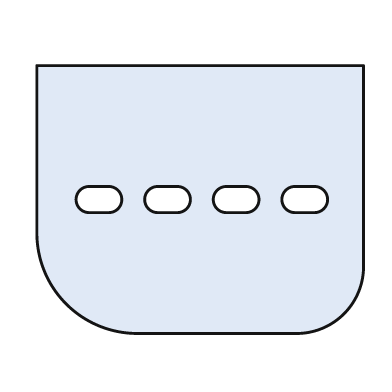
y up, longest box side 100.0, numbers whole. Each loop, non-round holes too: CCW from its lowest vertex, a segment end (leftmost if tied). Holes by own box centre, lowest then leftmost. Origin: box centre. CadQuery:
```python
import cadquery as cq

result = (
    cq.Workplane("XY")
    .moveTo(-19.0, -41.0)
    .lineTo(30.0, -41.0)
    .threePointArc((44.0, -35.0), (50.0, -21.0))
    .lineTo(50.0, 41.0)
    .lineTo(-50.0, 41.0)
    .lineTo(-50.0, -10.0)
    .threePointArc((-41.0, -32.0), (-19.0, -41.0))
    .close()
    .moveTo(-34.0, -4.0)
    .lineTo(-28.0, -4.0)
    .threePointArc((-24.0, 0.0), (-28.0, 4.0))
    .lineTo(-34.0, 4.0)
    .threePointArc((-38.0, 0.0), (-34.0, -4.0))
    .close()
    .moveTo(-13.0, -4.0)
    .lineTo(-7.0, -4.0)
    .threePointArc((-3.0, 0.0), (-7.0, 4.0))
    .lineTo(-13.0, 4.0)
    .threePointArc((-17.0, 0.0), (-13.0, -4.0))
    .close()
    .moveTo(8.0, -4.0)
    .lineTo(14.0, -4.0)
    .threePointArc((18.0, 0.0), (14.0, 4.0))
    .lineTo(8.0, 4.0)
    .threePointArc((4.0, 0.0), (8.0, -4.0))
    .close()
    .moveTo(29.0, -4.0)
    .lineTo(35.0, -4.0)
    .threePointArc((39.0, 0.0), (35.0, 4.0))
    .lineTo(29.0, 4.0)
    .threePointArc((25.0, 0.0), (29.0, -4.0))
    .close()
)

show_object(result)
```